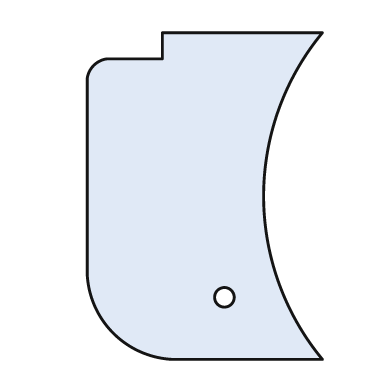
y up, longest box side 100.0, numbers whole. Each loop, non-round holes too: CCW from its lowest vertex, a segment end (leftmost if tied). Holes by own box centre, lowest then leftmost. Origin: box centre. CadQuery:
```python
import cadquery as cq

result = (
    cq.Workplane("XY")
    .moveTo(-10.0, -50.0)
    .lineTo(36.0, -50.0)
    .threePointArc((18.0, 0.0), (36.0, 50.0))
    .lineTo(-13.0, 50.0)
    .lineTo(-13.0, 42.0)
    .lineTo(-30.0, 42.0)
    .threePointArc((-34.0, 40.0), (-36.0, 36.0))
    .lineTo(-36.0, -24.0)
    .threePointArc((-28.0, -42.0), (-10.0, -50.0))
    .close()
    .moveTo(6.0, -31.0)
    .circle(3.0)
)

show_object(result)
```